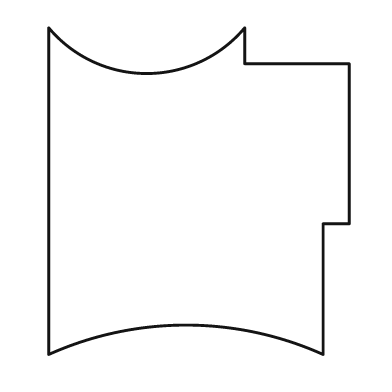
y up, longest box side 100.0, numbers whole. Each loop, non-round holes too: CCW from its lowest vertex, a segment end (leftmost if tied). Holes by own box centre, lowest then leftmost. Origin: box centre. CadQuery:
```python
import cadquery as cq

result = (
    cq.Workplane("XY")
    .moveTo(-46.0, -50.0)
    .threePointArc((-4.0, -41.0), (38.0, -50.0))
    .lineTo(38.0, -10.0)
    .lineTo(46.0, -10.0)
    .lineTo(46.0, 39.0)
    .lineTo(14.0, 39.0)
    .lineTo(14.0, 50.0)
    .threePointArc((-16.0, 36.0), (-46.0, 50.0))
    .close()
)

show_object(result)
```